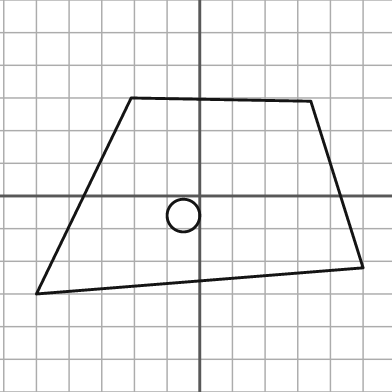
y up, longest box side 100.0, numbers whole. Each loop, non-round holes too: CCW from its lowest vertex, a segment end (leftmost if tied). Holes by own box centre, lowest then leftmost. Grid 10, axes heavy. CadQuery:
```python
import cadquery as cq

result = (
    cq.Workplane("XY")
    .moveTo(-50.0, -30.0)
    .lineTo(50.0, -22.0)
    .lineTo(34.0, 29.0)
    .lineTo(-21.0, 30.0)
    .close()
    .moveTo(-5.0, -6.0)
    .circle(5.0)
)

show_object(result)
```